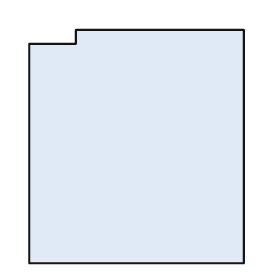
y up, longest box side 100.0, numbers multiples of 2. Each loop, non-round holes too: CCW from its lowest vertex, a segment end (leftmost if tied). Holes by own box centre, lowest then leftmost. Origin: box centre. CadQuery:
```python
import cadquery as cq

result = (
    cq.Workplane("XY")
    .moveTo(-46.0, -50.0)
    .lineTo(46.0, -50.0)
    .lineTo(46.0, 50.0)
    .lineTo(-26.0, 50.0)
    .lineTo(-26.0, 44.0)
    .lineTo(-46.0, 44.0)
    .close()
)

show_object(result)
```